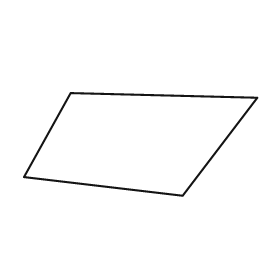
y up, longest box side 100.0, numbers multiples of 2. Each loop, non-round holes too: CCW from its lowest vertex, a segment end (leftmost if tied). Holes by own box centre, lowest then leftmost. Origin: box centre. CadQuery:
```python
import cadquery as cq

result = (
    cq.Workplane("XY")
    .moveTo(18.0, -22.0)
    .lineTo(50.0, 20.0)
    .lineTo(-30.0, 22.0)
    .lineTo(-50.0, -14.0)
    .close()
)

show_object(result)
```